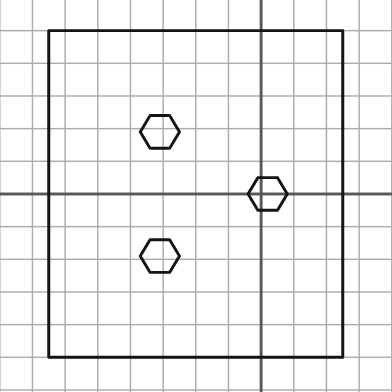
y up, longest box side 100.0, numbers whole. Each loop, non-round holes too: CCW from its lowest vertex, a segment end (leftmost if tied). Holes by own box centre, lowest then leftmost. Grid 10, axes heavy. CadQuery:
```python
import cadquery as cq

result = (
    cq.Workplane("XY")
    .moveTo(-65.0, -50.0)
    .lineTo(25.0, -50.0)
    .lineTo(25.0, 50.0)
    .lineTo(-65.0, 50.0)
    .close()
    .moveTo(-34.0, -24.0)
    .lineTo(-28.0, -24.0)
    .lineTo(-25.0, -19.0)
    .lineTo(-28.0, -14.0)
    .lineTo(-34.0, -14.0)
    .lineTo(-37.0, -19.0)
    .close()
    .moveTo(-1.0, -5.0)
    .lineTo(5.0, -5.0)
    .lineTo(8.0, 0.0)
    .lineTo(5.0, 5.0)
    .lineTo(-1.0, 5.0)
    .lineTo(-4.0, 0.0)
    .close()
    .moveTo(-34.0, 14.0)
    .lineTo(-28.0, 14.0)
    .lineTo(-25.0, 19.0)
    .lineTo(-28.0, 24.0)
    .lineTo(-34.0, 24.0)
    .lineTo(-37.0, 19.0)
    .close()
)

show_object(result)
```